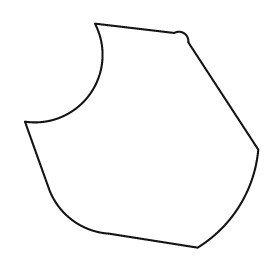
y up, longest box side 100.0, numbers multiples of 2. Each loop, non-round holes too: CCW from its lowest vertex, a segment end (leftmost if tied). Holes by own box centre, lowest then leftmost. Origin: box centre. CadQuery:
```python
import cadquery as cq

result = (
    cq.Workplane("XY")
    .moveTo(24.0, -48.0)
    .threePointArc((42.0, -30.0), (50.0, -6.0))
    .lineTo(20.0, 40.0)
    .threePointArc((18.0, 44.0), (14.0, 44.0))
    .lineTo(-20.0, 48.0)
    .threePointArc((-22.0, 18.0), (-50.0, 6.0))
    .lineTo(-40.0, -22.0)
    .threePointArc((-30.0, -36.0), (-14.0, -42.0))
    .close()
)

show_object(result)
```